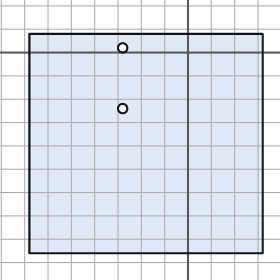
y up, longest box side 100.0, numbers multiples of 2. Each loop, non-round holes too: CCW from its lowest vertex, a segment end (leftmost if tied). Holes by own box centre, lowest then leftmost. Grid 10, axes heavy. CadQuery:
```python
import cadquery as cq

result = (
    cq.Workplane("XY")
    .moveTo(-68.0, -86.0)
    .lineTo(32.0, -86.0)
    .lineTo(32.0, 8.0)
    .lineTo(-68.0, 8.0)
    .close()
    .moveTo(-28.0, -24.0)
    .circle(2.0)
    .moveTo(-28.0, 2.0)
    .circle(2.0)
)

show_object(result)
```